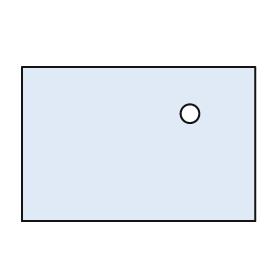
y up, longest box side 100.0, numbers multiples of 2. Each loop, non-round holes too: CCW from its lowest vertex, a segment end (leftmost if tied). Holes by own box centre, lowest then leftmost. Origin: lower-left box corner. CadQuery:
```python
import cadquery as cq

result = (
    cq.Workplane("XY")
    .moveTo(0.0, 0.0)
    .lineTo(100.0, 0.0)
    .lineTo(100.0, 66.0)
    .lineTo(0.0, 66.0)
    .close()
    .moveTo(72.0, 46.0)
    .circle(4.0)
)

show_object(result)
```